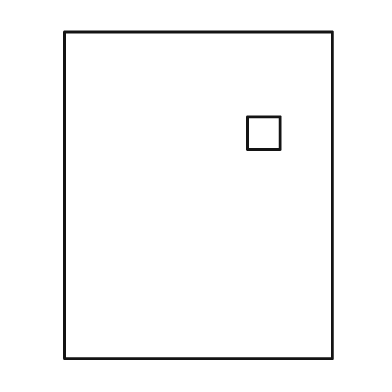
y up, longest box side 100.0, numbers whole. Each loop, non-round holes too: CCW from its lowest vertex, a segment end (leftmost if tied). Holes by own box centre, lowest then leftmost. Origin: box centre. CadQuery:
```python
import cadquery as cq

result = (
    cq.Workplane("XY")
    .moveTo(-41.0, -50.0)
    .lineTo(41.0, -50.0)
    .lineTo(41.0, 50.0)
    .lineTo(-41.0, 50.0)
    .close()
    .moveTo(15.0, 14.0)
    .lineTo(25.0, 14.0)
    .lineTo(25.0, 24.0)
    .lineTo(15.0, 24.0)
    .close()
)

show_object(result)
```